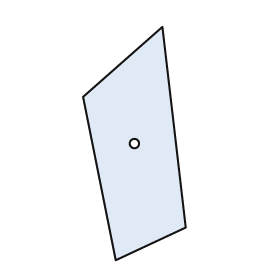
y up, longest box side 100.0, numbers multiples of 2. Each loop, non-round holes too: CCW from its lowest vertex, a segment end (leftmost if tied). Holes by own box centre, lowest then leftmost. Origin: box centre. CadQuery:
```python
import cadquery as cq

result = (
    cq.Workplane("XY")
    .moveTo(-8.0, -50.0)
    .lineTo(22.0, -36.0)
    .lineTo(12.0, 50.0)
    .lineTo(-22.0, 20.0)
    .close()
    .moveTo(0.0, 0.0)
    .circle(2.0)
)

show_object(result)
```